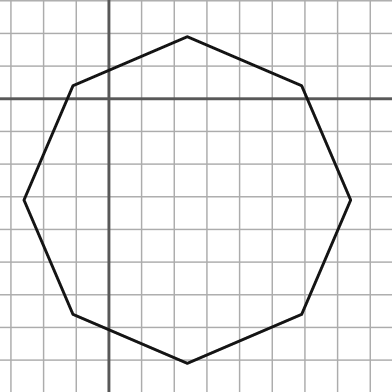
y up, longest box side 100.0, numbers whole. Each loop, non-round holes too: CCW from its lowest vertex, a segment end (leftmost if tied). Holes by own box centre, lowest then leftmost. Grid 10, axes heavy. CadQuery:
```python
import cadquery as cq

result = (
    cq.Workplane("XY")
    .moveTo(24.0, -81.0)
    .lineTo(59.0, -66.0)
    .lineTo(74.0, -31.0)
    .lineTo(59.0, 4.0)
    .lineTo(24.0, 19.0)
    .lineTo(-11.0, 4.0)
    .lineTo(-26.0, -31.0)
    .lineTo(-11.0, -66.0)
    .close()
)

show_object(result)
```